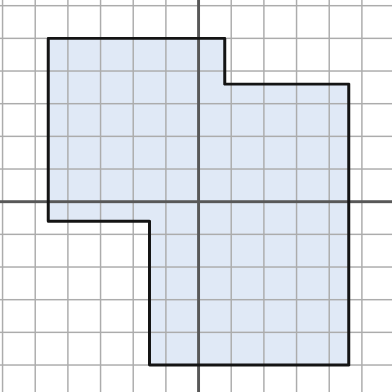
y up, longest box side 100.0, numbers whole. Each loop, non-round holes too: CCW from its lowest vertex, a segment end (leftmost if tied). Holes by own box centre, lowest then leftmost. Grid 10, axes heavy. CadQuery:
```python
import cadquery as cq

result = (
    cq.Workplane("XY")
    .moveTo(-15.0, -50.0)
    .lineTo(46.0, -50.0)
    .lineTo(46.0, 36.0)
    .lineTo(8.0, 36.0)
    .lineTo(8.0, 50.0)
    .lineTo(-46.0, 50.0)
    .lineTo(-46.0, -6.0)
    .lineTo(-15.0, -6.0)
    .close()
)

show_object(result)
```